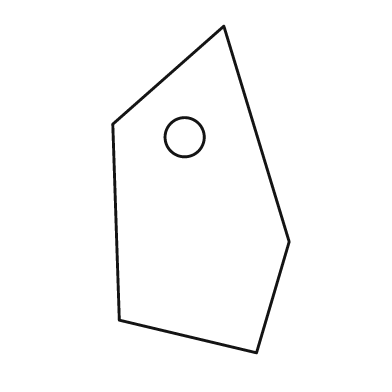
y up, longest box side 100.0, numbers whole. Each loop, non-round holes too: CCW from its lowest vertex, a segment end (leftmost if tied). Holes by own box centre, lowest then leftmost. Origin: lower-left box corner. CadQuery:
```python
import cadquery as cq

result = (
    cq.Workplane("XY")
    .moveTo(44.0, 0.0)
    .lineTo(54.0, 34.0)
    .lineTo(34.0, 100.0)
    .lineTo(0.0, 70.0)
    .lineTo(2.0, 10.0)
    .close()
    .moveTo(22.0, 66.0)
    .circle(6.0)
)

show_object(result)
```